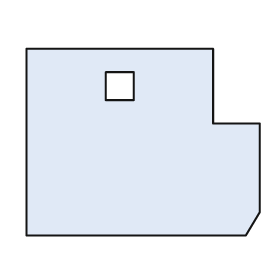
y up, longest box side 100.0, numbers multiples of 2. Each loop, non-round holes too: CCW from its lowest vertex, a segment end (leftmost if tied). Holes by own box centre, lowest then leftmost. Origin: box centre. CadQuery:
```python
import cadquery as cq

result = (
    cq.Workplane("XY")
    .moveTo(-50.0, -40.0)
    .lineTo(44.0, -40.0)
    .lineTo(50.0, -30.0)
    .lineTo(50.0, 8.0)
    .lineTo(30.0, 8.0)
    .lineTo(30.0, 40.0)
    .lineTo(-50.0, 40.0)
    .close()
    .moveTo(-16.0, 18.0)
    .lineTo(-4.0, 18.0)
    .lineTo(-4.0, 30.0)
    .lineTo(-16.0, 30.0)
    .close()
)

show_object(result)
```